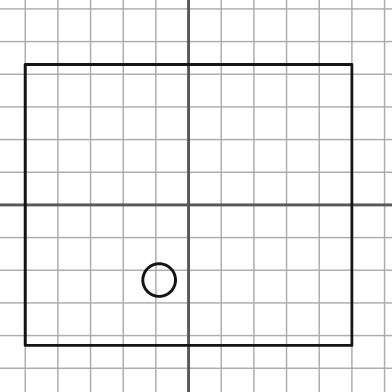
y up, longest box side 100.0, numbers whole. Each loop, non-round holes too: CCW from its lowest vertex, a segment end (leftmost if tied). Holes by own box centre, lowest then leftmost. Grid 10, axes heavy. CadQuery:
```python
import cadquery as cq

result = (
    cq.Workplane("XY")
    .moveTo(-50.0, -43.0)
    .lineTo(50.0, -43.0)
    .lineTo(50.0, 43.0)
    .lineTo(-50.0, 43.0)
    .close()
    .moveTo(-9.0, -23.0)
    .circle(5.0)
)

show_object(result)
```